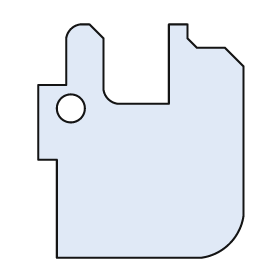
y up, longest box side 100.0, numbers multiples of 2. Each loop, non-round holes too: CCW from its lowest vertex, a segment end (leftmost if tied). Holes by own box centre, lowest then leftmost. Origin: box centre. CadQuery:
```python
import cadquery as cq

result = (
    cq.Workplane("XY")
    .moveTo(-36.0, -50.0)
    .lineTo(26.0, -50.0)
    .threePointArc((38.0, -44.0), (44.0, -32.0))
    .lineTo(44.0, 32.0)
    .lineTo(36.0, 40.0)
    .lineTo(24.0, 40.0)
    .lineTo(20.0, 44.0)
    .lineTo(20.0, 50.0)
    .lineTo(12.0, 50.0)
    .lineTo(12.0, 16.0)
    .lineTo(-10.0, 16.0)
    .threePointArc((-14.0, 18.0), (-16.0, 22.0))
    .lineTo(-16.0, 44.0)
    .lineTo(-22.0, 50.0)
    .lineTo(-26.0, 50.0)
    .threePointArc((-30.0, 48.0), (-32.0, 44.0))
    .lineTo(-32.0, 24.0)
    .lineTo(-44.0, 24.0)
    .lineTo(-44.0, -8.0)
    .lineTo(-36.0, -8.0)
    .close()
    .moveTo(-30.0, 14.0)
    .circle(6.0)
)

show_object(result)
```